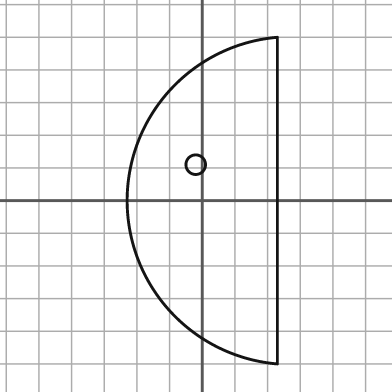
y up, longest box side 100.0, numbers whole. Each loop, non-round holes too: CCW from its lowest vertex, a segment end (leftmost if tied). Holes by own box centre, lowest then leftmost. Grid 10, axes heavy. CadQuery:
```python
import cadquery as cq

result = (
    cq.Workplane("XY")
    .moveTo(23.0, -50.0)
    .lineTo(23.0, 50.0)
    .threePointArc((-23.0, 0.0), (23.0, -50.0))
    .close()
    .moveTo(-2.0, 11.0)
    .circle(3.0)
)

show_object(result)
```